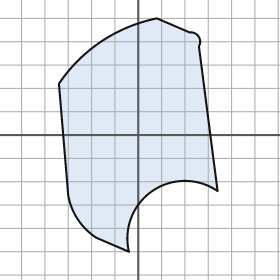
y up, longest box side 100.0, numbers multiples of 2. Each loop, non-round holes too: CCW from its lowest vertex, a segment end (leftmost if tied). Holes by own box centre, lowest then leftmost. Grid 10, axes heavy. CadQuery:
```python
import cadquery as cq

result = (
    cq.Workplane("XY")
    .moveTo(-4.0, -50.0)
    .threePointArc((6.0, -24.0), (34.0, -24.0))
    .lineTo(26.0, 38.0)
    .threePointArc((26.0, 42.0), (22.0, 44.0))
    .lineTo(8.0, 50.0)
    .threePointArc((-16.0, 40.0), (-34.0, 22.0))
    .lineTo(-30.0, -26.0)
    .threePointArc((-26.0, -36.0), (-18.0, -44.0))
    .close()
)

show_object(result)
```